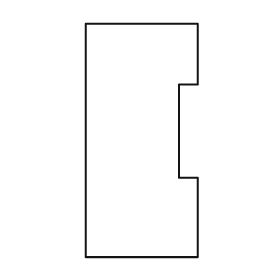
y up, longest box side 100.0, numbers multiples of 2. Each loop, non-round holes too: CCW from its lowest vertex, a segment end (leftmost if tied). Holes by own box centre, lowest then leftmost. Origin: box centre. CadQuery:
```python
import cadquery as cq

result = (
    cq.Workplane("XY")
    .moveTo(-24.0, -50.0)
    .lineTo(24.0, -50.0)
    .lineTo(24.0, -16.0)
    .lineTo(16.0, -16.0)
    .lineTo(16.0, 24.0)
    .lineTo(24.0, 24.0)
    .lineTo(24.0, 50.0)
    .lineTo(-24.0, 50.0)
    .close()
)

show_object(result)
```